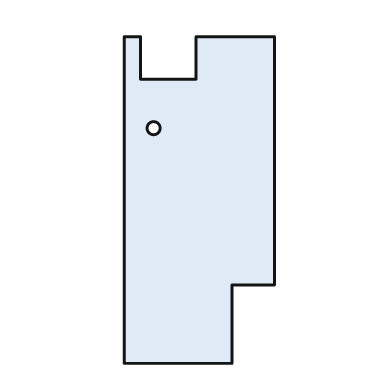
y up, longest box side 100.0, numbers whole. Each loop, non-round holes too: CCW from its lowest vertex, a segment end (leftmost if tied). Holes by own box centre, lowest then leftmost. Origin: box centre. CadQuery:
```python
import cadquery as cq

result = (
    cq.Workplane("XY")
    .moveTo(-23.0, -50.0)
    .lineTo(10.0, -50.0)
    .lineTo(10.0, -26.0)
    .lineTo(23.0, -26.0)
    .lineTo(23.0, 50.0)
    .lineTo(-1.0, 50.0)
    .lineTo(-1.0, 37.0)
    .lineTo(-18.0, 37.0)
    .lineTo(-18.0, 50.0)
    .lineTo(-23.0, 50.0)
    .close()
    .moveTo(-14.0, 22.0)
    .circle(2.0)
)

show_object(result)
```